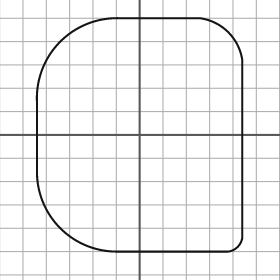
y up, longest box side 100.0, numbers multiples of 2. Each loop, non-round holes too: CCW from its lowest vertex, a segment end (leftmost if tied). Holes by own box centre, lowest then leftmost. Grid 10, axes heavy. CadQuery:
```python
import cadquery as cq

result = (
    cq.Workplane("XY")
    .moveTo(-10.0, -50.0)
    .lineTo(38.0, -50.0)
    .threePointArc((42.0, -48.0), (44.0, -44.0))
    .lineTo(44.0, 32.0)
    .threePointArc((38.0, 44.0), (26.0, 50.0))
    .lineTo(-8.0, 50.0)
    .threePointArc((-34.0, 40.0), (-44.0, 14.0))
    .lineTo(-44.0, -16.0)
    .threePointArc((-34.0, -40.0), (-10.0, -50.0))
    .close()
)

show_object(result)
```